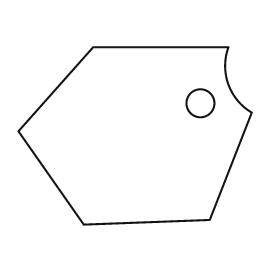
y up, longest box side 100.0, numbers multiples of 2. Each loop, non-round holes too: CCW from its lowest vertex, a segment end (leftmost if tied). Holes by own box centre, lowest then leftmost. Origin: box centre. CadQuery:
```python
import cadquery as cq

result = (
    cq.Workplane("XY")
    .moveTo(-22.0, -38.0)
    .lineTo(32.0, -36.0)
    .lineTo(50.0, 10.0)
    .threePointArc((40.0, 22.0), (40.0, 38.0))
    .lineTo(-18.0, 38.0)
    .lineTo(-50.0, 2.0)
    .close()
    .moveTo(28.0, 14.0)
    .circle(6.0)
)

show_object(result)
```